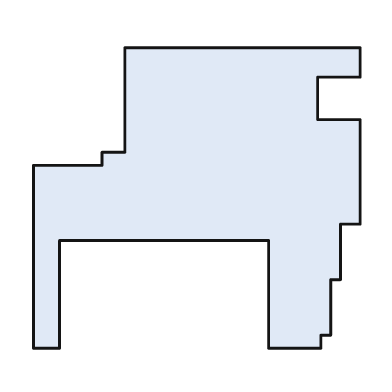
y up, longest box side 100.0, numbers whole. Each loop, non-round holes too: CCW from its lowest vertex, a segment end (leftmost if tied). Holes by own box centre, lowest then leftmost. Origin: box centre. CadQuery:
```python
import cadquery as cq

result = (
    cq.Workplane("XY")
    .moveTo(-50.0, -46.0)
    .lineTo(-42.0, -46.0)
    .lineTo(-42.0, -13.0)
    .lineTo(22.0, -13.0)
    .lineTo(22.0, -46.0)
    .lineTo(38.0, -46.0)
    .lineTo(38.0, -42.0)
    .lineTo(41.0, -42.0)
    .lineTo(41.0, -25.0)
    .lineTo(44.0, -25.0)
    .lineTo(44.0, -8.0)
    .lineTo(50.0, -8.0)
    .lineTo(50.0, 24.0)
    .lineTo(37.0, 24.0)
    .lineTo(37.0, 37.0)
    .lineTo(50.0, 37.0)
    .lineTo(50.0, 46.0)
    .lineTo(-22.0, 46.0)
    .lineTo(-22.0, 14.0)
    .lineTo(-29.0, 14.0)
    .lineTo(-29.0, 10.0)
    .lineTo(-50.0, 10.0)
    .close()
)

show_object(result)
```